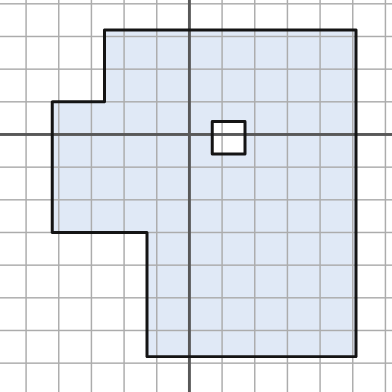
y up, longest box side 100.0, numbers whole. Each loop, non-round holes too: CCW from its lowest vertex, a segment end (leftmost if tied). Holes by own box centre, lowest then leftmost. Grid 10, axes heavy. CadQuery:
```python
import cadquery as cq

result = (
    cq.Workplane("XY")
    .moveTo(-13.0, -68.0)
    .lineTo(51.0, -68.0)
    .lineTo(51.0, 32.0)
    .lineTo(-26.0, 32.0)
    .lineTo(-26.0, 10.0)
    .lineTo(-42.0, 10.0)
    .lineTo(-42.0, -30.0)
    .lineTo(-13.0, -30.0)
    .close()
    .moveTo(7.0, -6.0)
    .lineTo(17.0, -6.0)
    .lineTo(17.0, 4.0)
    .lineTo(7.0, 4.0)
    .close()
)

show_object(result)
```